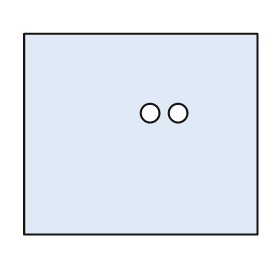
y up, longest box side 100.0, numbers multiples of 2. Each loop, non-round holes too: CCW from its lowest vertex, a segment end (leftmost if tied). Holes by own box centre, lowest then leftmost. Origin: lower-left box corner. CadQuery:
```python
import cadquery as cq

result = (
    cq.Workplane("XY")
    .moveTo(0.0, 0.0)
    .lineTo(100.0, 0.0)
    .lineTo(100.0, 86.0)
    .lineTo(0.0, 86.0)
    .close()
    .moveTo(54.0, 52.0)
    .circle(4.0)
    .moveTo(66.0, 52.0)
    .circle(4.0)
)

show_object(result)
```